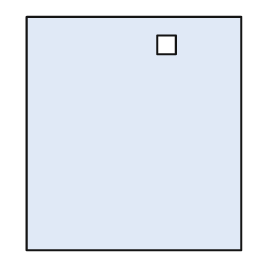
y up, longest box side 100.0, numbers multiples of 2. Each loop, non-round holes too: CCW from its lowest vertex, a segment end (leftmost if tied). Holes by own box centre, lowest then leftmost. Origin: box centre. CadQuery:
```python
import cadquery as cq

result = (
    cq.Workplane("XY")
    .moveTo(-46.0, -50.0)
    .lineTo(46.0, -50.0)
    .lineTo(46.0, 50.0)
    .lineTo(-46.0, 50.0)
    .close()
    .moveTo(10.0, 34.0)
    .lineTo(18.0, 34.0)
    .lineTo(18.0, 42.0)
    .lineTo(10.0, 42.0)
    .close()
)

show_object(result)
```